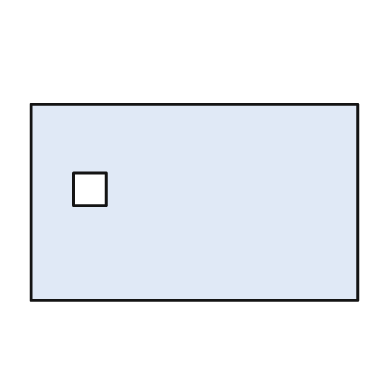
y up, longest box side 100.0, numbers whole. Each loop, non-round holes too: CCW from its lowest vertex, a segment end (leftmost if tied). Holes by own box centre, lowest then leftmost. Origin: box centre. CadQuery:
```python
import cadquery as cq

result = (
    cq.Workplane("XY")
    .moveTo(-50.0, -30.0)
    .lineTo(50.0, -30.0)
    .lineTo(50.0, 30.0)
    .lineTo(-50.0, 30.0)
    .close()
    .moveTo(-37.0, -1.0)
    .lineTo(-27.0, -1.0)
    .lineTo(-27.0, 9.0)
    .lineTo(-37.0, 9.0)
    .close()
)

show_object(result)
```